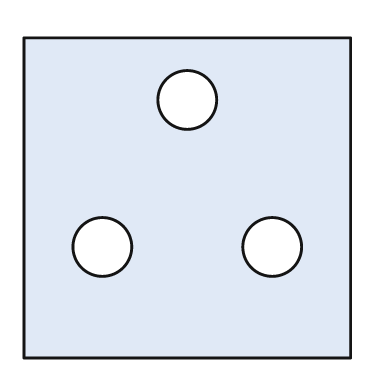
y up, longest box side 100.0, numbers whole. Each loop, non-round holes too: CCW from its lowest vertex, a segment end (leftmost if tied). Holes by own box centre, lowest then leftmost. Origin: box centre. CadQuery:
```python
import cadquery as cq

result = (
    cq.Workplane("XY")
    .moveTo(-50.0, -49.0)
    .lineTo(50.0, -49.0)
    .lineTo(50.0, 49.0)
    .lineTo(-50.0, 49.0)
    .close()
    .moveTo(-26.0, -15.0)
    .circle(9.0)
    .moveTo(26.0, -15.0)
    .circle(9.0)
    .moveTo(0.0, 30.0)
    .circle(9.0)
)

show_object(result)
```